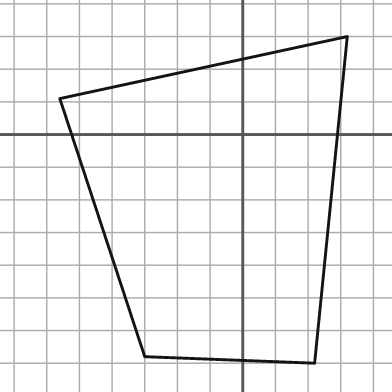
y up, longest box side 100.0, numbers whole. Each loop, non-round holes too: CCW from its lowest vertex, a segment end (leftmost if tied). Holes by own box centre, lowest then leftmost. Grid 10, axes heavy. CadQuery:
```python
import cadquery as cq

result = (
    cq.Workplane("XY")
    .moveTo(22.0, -70.0)
    .lineTo(32.0, 30.0)
    .lineTo(-56.0, 11.0)
    .lineTo(-30.0, -68.0)
    .close()
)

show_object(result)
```